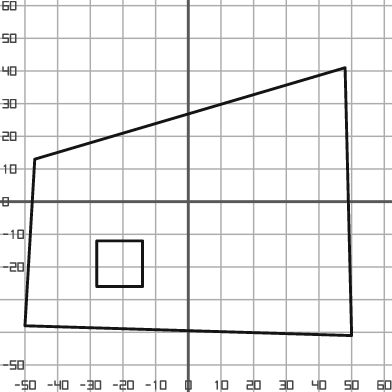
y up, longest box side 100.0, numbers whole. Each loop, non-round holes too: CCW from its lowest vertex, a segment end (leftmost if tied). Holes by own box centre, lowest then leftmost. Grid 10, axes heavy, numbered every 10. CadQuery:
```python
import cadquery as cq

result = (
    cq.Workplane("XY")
    .moveTo(50.0, -41.0)
    .lineTo(48.0, 41.0)
    .lineTo(-47.0, 13.0)
    .lineTo(-50.0, -38.0)
    .close()
    .moveTo(-28.0, -26.0)
    .lineTo(-14.0, -26.0)
    .lineTo(-14.0, -12.0)
    .lineTo(-28.0, -12.0)
    .close()
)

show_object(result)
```